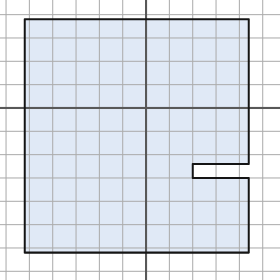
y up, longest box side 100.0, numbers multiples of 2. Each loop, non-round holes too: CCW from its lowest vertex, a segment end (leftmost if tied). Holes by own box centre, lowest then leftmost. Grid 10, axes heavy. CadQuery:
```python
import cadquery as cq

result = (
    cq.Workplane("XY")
    .moveTo(-52.0, -62.0)
    .lineTo(44.0, -62.0)
    .lineTo(44.0, -30.0)
    .lineTo(20.0, -30.0)
    .lineTo(20.0, -24.0)
    .lineTo(44.0, -24.0)
    .lineTo(44.0, 38.0)
    .lineTo(-52.0, 38.0)
    .close()
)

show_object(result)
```